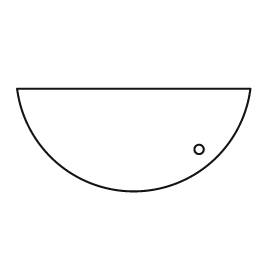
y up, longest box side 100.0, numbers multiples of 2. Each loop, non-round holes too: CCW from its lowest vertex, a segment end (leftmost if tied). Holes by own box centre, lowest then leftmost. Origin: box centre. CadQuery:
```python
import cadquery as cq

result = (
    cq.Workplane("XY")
    .moveTo(-50.0, 22.0)
    .threePointArc((0.0, -22.0), (50.0, 22.0))
    .close()
    .moveTo(28.0, -4.0)
    .circle(2.0)
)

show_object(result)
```